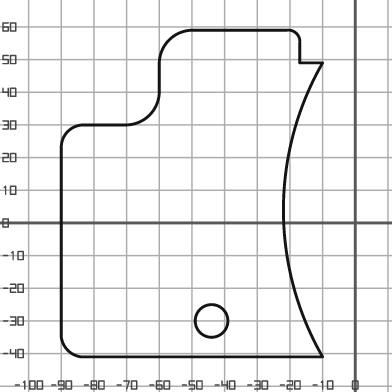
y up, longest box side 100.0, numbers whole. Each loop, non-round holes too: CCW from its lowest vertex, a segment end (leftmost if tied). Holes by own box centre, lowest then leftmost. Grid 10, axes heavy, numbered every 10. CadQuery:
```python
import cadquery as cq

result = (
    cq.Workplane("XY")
    .moveTo(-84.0, -41.0)
    .lineTo(-10.0, -41.0)
    .threePointArc((-22.0, 4.0), (-10.0, 49.0))
    .lineTo(-17.0, 49.0)
    .lineTo(-17.0, 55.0)
    .threePointArc((-18.0, 58.0), (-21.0, 59.0))
    .lineTo(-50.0, 59.0)
    .threePointArc((-57.0, 56.0), (-60.0, 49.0))
    .lineTo(-60.0, 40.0)
    .threePointArc((-63.0, 33.0), (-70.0, 30.0))
    .lineTo(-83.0, 30.0)
    .threePointArc((-88.0, 28.0), (-90.0, 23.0))
    .lineTo(-90.0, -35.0)
    .threePointArc((-88.0, -39.0), (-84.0, -41.0))
    .close()
    .moveTo(-44.0, -30.0)
    .circle(5.0)
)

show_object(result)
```